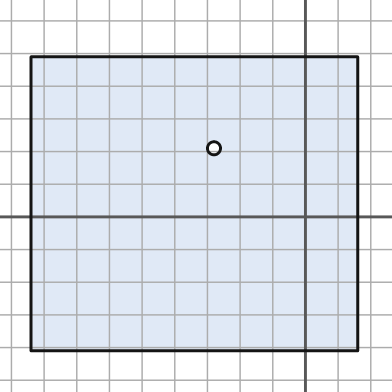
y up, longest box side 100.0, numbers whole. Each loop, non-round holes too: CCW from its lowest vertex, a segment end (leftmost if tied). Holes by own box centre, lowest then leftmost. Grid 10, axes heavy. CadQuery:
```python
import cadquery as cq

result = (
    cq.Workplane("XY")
    .moveTo(-84.0, -41.0)
    .lineTo(16.0, -41.0)
    .lineTo(16.0, 49.0)
    .lineTo(-84.0, 49.0)
    .close()
    .moveTo(-28.0, 21.0)
    .circle(2.0)
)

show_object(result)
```